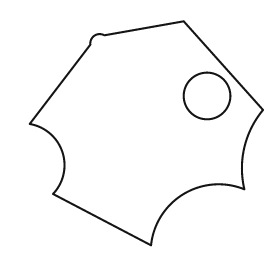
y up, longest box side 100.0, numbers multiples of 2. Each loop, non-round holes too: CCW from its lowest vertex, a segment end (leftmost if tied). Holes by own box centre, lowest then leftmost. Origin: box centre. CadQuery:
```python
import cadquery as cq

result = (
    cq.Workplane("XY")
    .moveTo(2.0, -48.0)
    .threePointArc((16.0, -26.0), (42.0, -24.0))
    .threePointArc((42.0, -6.0), (50.0, 10.0))
    .lineTo(16.0, 48.0)
    .lineTo(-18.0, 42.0)
    .threePointArc((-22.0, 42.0), (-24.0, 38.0))
    .lineTo(-50.0, 4.0)
    .threePointArc((-36.0, -8.0), (-40.0, -26.0))
    .close()
    .moveTo(26.0, 16.0)
    .circle(10.0)
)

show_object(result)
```